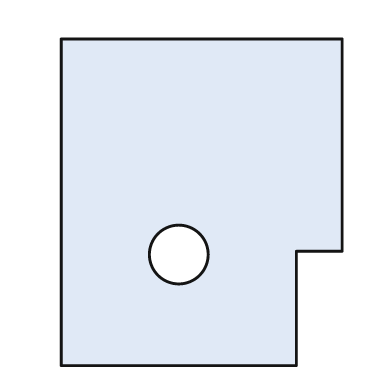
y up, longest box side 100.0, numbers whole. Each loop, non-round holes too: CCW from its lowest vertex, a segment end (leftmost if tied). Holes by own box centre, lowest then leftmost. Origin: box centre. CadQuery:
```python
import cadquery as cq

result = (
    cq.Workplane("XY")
    .moveTo(-43.0, -50.0)
    .lineTo(29.0, -50.0)
    .lineTo(29.0, -15.0)
    .lineTo(43.0, -15.0)
    .lineTo(43.0, 50.0)
    .lineTo(-43.0, 50.0)
    .close()
    .moveTo(-7.0, -16.0)
    .circle(9.0)
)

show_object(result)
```